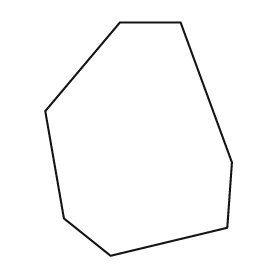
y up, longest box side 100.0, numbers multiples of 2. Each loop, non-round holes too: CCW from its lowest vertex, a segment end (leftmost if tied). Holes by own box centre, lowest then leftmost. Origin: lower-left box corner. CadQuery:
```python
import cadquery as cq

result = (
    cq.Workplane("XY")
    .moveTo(28.0, 0.0)
    .lineTo(78.0, 12.0)
    .lineTo(80.0, 40.0)
    .lineTo(58.0, 100.0)
    .lineTo(32.0, 100.0)
    .lineTo(0.0, 62.0)
    .lineTo(8.0, 16.0)
    .close()
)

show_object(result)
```